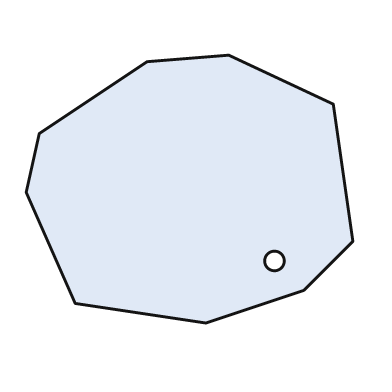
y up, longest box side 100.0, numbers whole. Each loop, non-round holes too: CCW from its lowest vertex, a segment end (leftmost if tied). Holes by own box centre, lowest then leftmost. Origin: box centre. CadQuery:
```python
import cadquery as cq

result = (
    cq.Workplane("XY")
    .moveTo(5.0, -41.0)
    .lineTo(35.0, -31.0)
    .lineTo(50.0, -16.0)
    .lineTo(44.0, 26.0)
    .lineTo(12.0, 41.0)
    .lineTo(-13.0, 39.0)
    .lineTo(-46.0, 17.0)
    .lineTo(-50.0, -1.0)
    .lineTo(-35.0, -35.0)
    .close()
    .moveTo(26.0, -22.0)
    .circle(3.0)
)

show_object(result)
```